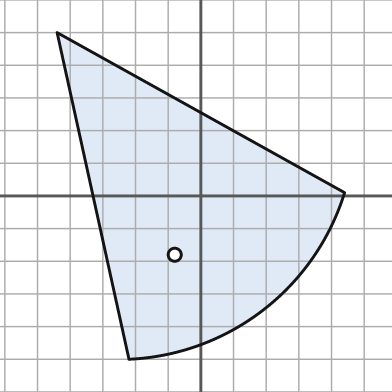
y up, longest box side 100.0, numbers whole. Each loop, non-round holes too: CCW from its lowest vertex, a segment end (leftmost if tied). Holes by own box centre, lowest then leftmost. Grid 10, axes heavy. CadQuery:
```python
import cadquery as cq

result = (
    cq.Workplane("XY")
    .moveTo(-22.0, -50.0)
    .threePointArc((19.0, -35.0), (44.0, 1.0))
    .lineTo(-44.0, 50.0)
    .close()
    .moveTo(-8.0, -18.0)
    .circle(2.0)
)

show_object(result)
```